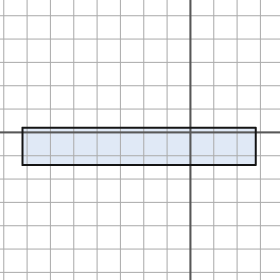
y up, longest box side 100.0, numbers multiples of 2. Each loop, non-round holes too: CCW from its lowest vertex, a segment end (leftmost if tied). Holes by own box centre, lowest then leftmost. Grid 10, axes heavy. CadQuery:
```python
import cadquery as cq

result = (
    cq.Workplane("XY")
    .moveTo(-72.0, -14.0)
    .lineTo(28.0, -14.0)
    .lineTo(28.0, 2.0)
    .lineTo(-72.0, 2.0)
    .close()
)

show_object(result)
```